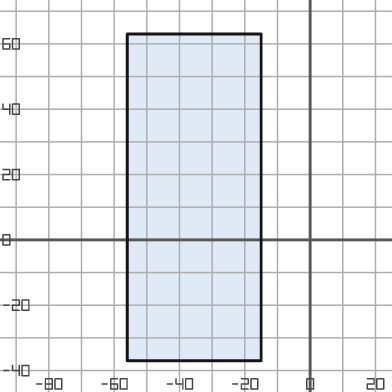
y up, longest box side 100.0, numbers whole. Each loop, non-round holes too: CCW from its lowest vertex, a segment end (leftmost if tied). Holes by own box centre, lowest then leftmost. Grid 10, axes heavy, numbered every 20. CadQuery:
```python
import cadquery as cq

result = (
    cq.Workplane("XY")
    .moveTo(-56.0, -37.0)
    .lineTo(-15.0, -37.0)
    .lineTo(-15.0, 63.0)
    .lineTo(-56.0, 63.0)
    .close()
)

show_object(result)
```